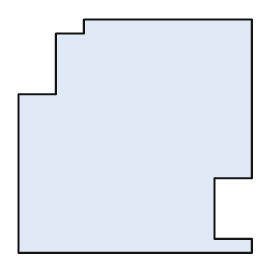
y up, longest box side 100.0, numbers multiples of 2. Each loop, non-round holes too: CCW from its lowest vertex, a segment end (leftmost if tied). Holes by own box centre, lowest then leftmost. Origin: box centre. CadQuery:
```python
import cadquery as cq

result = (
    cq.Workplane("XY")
    .moveTo(-50.0, -50.0)
    .lineTo(50.0, -50.0)
    .lineTo(50.0, -44.0)
    .lineTo(34.0, -44.0)
    .lineTo(34.0, -18.0)
    .lineTo(50.0, -18.0)
    .lineTo(50.0, 50.0)
    .lineTo(-22.0, 50.0)
    .lineTo(-22.0, 44.0)
    .lineTo(-34.0, 44.0)
    .lineTo(-34.0, 18.0)
    .lineTo(-50.0, 18.0)
    .close()
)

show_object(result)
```